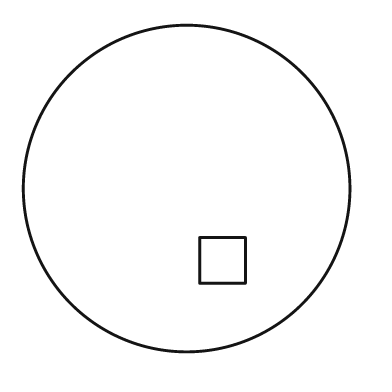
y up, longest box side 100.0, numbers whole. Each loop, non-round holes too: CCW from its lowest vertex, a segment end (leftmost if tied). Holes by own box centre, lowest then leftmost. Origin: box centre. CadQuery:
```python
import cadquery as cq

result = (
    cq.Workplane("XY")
    .moveTo(0.0, 0.0)
    .circle(50.0)
    .moveTo(4.0, -29.0)
    .lineTo(18.0, -29.0)
    .lineTo(18.0, -15.0)
    .lineTo(4.0, -15.0)
    .close()
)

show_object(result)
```